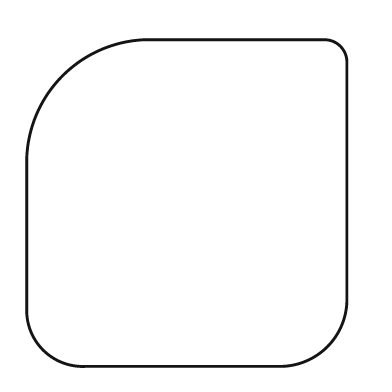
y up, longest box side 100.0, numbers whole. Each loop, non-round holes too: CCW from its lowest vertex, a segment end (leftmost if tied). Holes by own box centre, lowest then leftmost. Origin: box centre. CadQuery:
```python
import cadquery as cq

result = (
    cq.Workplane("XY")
    .moveTo(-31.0, -50.0)
    .lineTo(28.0, -50.0)
    .threePointArc((43.0, -44.0), (49.0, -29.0))
    .lineTo(49.0, 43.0)
    .threePointArc((47.0, 48.0), (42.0, 50.0))
    .lineTo(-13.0, 50.0)
    .threePointArc((-38.0, 39.0), (-49.0, 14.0))
    .lineTo(-49.0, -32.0)
    .threePointArc((-44.0, -45.0), (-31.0, -50.0))
    .close()
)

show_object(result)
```